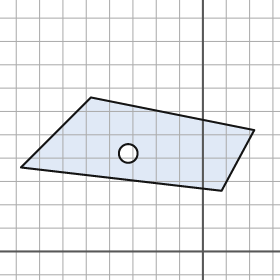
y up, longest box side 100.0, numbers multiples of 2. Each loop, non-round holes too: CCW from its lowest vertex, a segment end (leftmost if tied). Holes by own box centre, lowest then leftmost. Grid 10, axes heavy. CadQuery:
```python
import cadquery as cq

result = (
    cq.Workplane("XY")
    .moveTo(8.0, 26.0)
    .lineTo(22.0, 52.0)
    .lineTo(-48.0, 66.0)
    .lineTo(-78.0, 36.0)
    .close()
    .moveTo(-32.0, 42.0)
    .circle(4.0)
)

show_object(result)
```